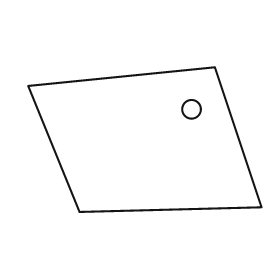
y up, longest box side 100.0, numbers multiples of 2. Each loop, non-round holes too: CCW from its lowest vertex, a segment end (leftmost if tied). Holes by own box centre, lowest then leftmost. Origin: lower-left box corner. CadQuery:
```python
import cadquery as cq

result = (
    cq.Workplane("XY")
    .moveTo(22.0, 0.0)
    .lineTo(100.0, 2.0)
    .lineTo(80.0, 62.0)
    .lineTo(0.0, 54.0)
    .close()
    .moveTo(70.0, 44.0)
    .circle(4.0)
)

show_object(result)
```